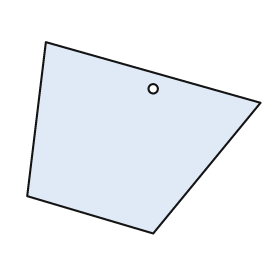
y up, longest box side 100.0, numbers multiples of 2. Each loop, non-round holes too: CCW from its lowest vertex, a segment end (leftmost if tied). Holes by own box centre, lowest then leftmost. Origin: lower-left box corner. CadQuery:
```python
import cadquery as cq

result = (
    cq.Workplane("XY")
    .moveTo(54.0, 0.0)
    .lineTo(100.0, 56.0)
    .lineTo(8.0, 82.0)
    .lineTo(0.0, 16.0)
    .close()
    .moveTo(54.0, 62.0)
    .circle(2.0)
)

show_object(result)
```